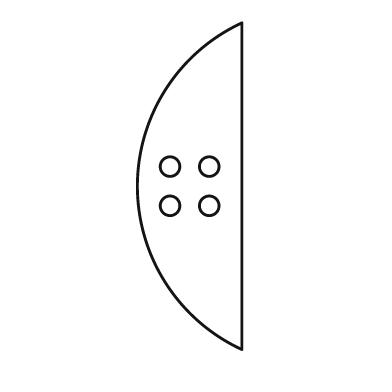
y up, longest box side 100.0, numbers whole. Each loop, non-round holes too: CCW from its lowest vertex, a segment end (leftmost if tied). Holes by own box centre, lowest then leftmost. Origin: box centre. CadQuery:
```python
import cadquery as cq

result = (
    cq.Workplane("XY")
    .moveTo(16.0, -50.0)
    .lineTo(16.0, 50.0)
    .threePointArc((-16.0, 0.0), (16.0, -50.0))
    .close()
    .moveTo(-6.0, -6.0)
    .circle(3.0)
    .moveTo(6.0, -6.0)
    .circle(3.0)
    .moveTo(-6.0, 6.0)
    .circle(3.0)
    .moveTo(6.0, 6.0)
    .circle(3.0)
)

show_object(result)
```